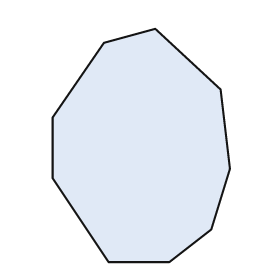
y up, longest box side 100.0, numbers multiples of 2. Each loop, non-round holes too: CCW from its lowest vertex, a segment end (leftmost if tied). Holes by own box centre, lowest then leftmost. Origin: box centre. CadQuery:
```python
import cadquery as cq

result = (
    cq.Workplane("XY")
    .moveTo(-14.0, -50.0)
    .lineTo(12.0, -50.0)
    .lineTo(30.0, -36.0)
    .lineTo(38.0, -10.0)
    .lineTo(34.0, 24.0)
    .lineTo(6.0, 50.0)
    .lineTo(-16.0, 44.0)
    .lineTo(-38.0, 12.0)
    .lineTo(-38.0, -14.0)
    .close()
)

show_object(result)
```